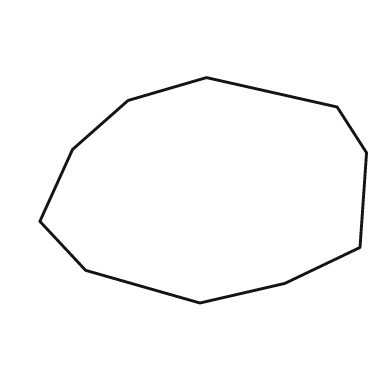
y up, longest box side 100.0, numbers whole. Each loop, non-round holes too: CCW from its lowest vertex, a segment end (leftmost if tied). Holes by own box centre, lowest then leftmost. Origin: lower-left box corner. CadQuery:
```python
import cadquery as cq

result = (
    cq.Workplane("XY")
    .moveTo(49.0, 0.0)
    .lineTo(75.0, 6.0)
    .lineTo(98.0, 17.0)
    .lineTo(100.0, 46.0)
    .lineTo(91.0, 60.0)
    .lineTo(51.0, 69.0)
    .lineTo(27.0, 62.0)
    .lineTo(10.0, 47.0)
    .lineTo(0.0, 25.0)
    .lineTo(14.0, 10.0)
    .close()
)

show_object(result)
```